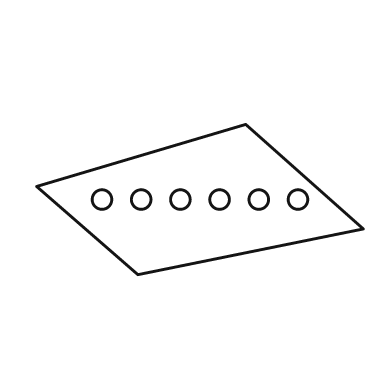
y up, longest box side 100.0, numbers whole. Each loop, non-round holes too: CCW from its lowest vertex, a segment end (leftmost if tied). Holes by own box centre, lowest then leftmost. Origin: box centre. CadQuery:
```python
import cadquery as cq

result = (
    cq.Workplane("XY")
    .moveTo(-19.0, -23.0)
    .lineTo(50.0, -9.0)
    .lineTo(14.0, 23.0)
    .lineTo(-50.0, 4.0)
    .close()
    .moveTo(-30.0, 0.0)
    .circle(3.0)
    .moveTo(-18.0, 0.0)
    .circle(3.0)
    .moveTo(-6.0, 0.0)
    .circle(3.0)
    .moveTo(6.0, 0.0)
    .circle(3.0)
    .moveTo(18.0, 0.0)
    .circle(3.0)
    .moveTo(30.0, 0.0)
    .circle(3.0)
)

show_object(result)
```